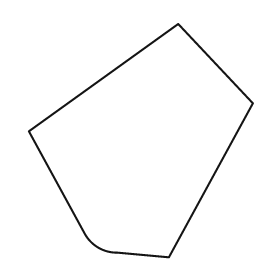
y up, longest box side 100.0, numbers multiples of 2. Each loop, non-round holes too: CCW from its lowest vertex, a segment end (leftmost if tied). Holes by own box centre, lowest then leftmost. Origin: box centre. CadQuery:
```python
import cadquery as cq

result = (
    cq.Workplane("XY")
    .moveTo(12.0, -50.0)
    .lineTo(48.0, 16.0)
    .lineTo(16.0, 50.0)
    .lineTo(-48.0, 4.0)
    .lineTo(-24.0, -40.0)
    .threePointArc((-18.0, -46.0), (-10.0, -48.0))
    .close()
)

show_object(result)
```